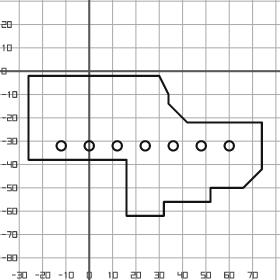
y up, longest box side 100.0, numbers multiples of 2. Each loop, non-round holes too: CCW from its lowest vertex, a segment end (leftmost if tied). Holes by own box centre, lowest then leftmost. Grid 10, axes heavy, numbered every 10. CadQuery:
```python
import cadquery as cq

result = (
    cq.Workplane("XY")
    .moveTo(16.0, -62.0)
    .lineTo(32.0, -62.0)
    .lineTo(32.0, -56.0)
    .lineTo(52.0, -56.0)
    .lineTo(52.0, -50.0)
    .lineTo(66.0, -50.0)
    .lineTo(74.0, -42.0)
    .lineTo(74.0, -22.0)
    .lineTo(42.0, -22.0)
    .lineTo(34.0, -14.0)
    .lineTo(34.0, -10.0)
    .lineTo(30.0, -2.0)
    .lineTo(-26.0, -2.0)
    .lineTo(-26.0, -38.0)
    .lineTo(16.0, -38.0)
    .close()
    .moveTo(-12.0, -32.0)
    .circle(2.0)
    .moveTo(0.0, -32.0)
    .circle(2.0)
    .moveTo(12.0, -32.0)
    .circle(2.0)
    .moveTo(24.0, -32.0)
    .circle(2.0)
    .moveTo(36.0, -32.0)
    .circle(2.0)
    .moveTo(48.0, -32.0)
    .circle(2.0)
    .moveTo(60.0, -32.0)
    .circle(2.0)
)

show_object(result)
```